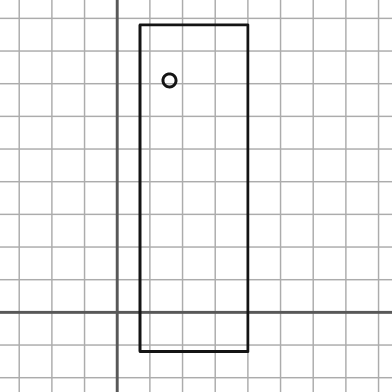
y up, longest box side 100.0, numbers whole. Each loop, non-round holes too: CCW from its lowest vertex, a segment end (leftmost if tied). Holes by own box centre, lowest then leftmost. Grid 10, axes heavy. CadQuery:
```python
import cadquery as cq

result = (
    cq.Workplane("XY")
    .moveTo(7.0, -12.0)
    .lineTo(40.0, -12.0)
    .lineTo(40.0, 88.0)
    .lineTo(7.0, 88.0)
    .close()
    .moveTo(16.0, 71.0)
    .circle(2.0)
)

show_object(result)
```